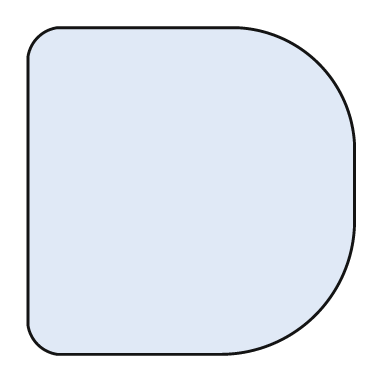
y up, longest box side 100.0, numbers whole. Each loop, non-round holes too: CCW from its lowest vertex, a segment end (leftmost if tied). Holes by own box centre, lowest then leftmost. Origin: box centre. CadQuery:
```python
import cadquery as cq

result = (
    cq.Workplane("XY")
    .moveTo(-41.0, -50.0)
    .lineTo(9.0, -50.0)
    .threePointArc((38.0, -38.0), (50.0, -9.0))
    .lineTo(50.0, 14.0)
    .threePointArc((39.0, 39.0), (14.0, 50.0))
    .lineTo(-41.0, 50.0)
    .threePointArc((-47.0, 47.0), (-50.0, 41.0))
    .lineTo(-50.0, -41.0)
    .threePointArc((-47.0, -47.0), (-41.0, -50.0))
    .close()
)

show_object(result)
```